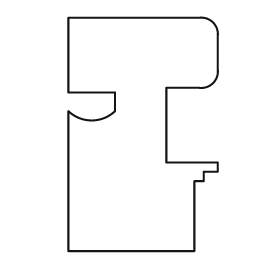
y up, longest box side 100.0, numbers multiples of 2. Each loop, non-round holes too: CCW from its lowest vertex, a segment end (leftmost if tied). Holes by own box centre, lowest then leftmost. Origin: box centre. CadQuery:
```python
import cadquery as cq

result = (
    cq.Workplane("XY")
    .moveTo(-32.0, -50.0)
    .lineTo(22.0, -50.0)
    .lineTo(22.0, -20.0)
    .lineTo(26.0, -20.0)
    .lineTo(26.0, -16.0)
    .lineTo(32.0, -16.0)
    .lineTo(32.0, -12.0)
    .lineTo(10.0, -12.0)
    .lineTo(10.0, 20.0)
    .lineTo(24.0, 20.0)
    .threePointArc((30.0, 22.0), (32.0, 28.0))
    .lineTo(32.0, 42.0)
    .threePointArc((30.0, 48.0), (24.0, 50.0))
    .lineTo(-32.0, 50.0)
    .lineTo(-32.0, 18.0)
    .lineTo(-12.0, 18.0)
    .lineTo(-12.0, 10.0)
    .threePointArc((-22.0, 6.0), (-32.0, 10.0))
    .close()
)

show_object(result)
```